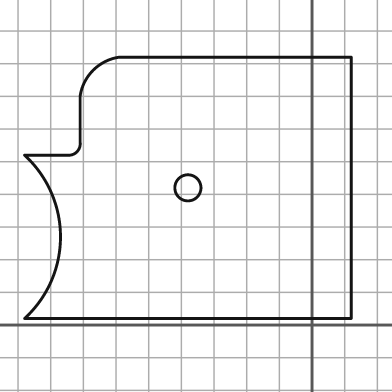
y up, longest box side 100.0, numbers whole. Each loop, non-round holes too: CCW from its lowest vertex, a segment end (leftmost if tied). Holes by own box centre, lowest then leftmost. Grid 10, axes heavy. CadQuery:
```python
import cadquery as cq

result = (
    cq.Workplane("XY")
    .moveTo(-88.0, 2.0)
    .lineTo(12.0, 2.0)
    .lineTo(12.0, 82.0)
    .lineTo(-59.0, 82.0)
    .threePointArc((-67.0, 78.0), (-71.0, 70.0))
    .lineTo(-71.0, 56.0)
    .threePointArc((-72.0, 53.0), (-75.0, 52.0))
    .lineTo(-88.0, 52.0)
    .threePointArc((-77.0, 27.0), (-88.0, 2.0))
    .close()
    .moveTo(-38.0, 42.0)
    .circle(4.0)
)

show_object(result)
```